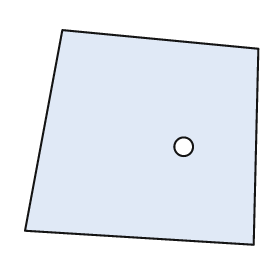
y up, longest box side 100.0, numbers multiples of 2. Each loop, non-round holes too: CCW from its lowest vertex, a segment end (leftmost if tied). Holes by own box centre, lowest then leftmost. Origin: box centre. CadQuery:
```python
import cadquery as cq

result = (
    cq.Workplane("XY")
    .moveTo(48.0, -46.0)
    .lineTo(50.0, 38.0)
    .lineTo(-34.0, 46.0)
    .lineTo(-50.0, -40.0)
    .close()
    .moveTo(18.0, -4.0)
    .circle(4.0)
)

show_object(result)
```